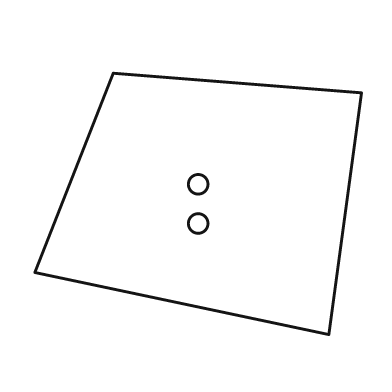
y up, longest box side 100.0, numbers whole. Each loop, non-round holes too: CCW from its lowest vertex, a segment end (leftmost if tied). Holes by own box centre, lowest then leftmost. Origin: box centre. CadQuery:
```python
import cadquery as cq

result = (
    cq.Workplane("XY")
    .moveTo(40.0, -40.0)
    .lineTo(50.0, 34.0)
    .lineTo(-26.0, 40.0)
    .lineTo(-50.0, -21.0)
    .close()
    .moveTo(0.0, -6.0)
    .circle(3.0)
    .moveTo(0.0, 6.0)
    .circle(3.0)
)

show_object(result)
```